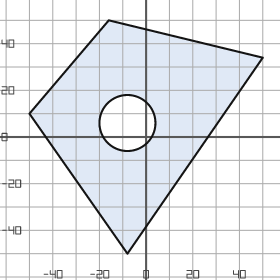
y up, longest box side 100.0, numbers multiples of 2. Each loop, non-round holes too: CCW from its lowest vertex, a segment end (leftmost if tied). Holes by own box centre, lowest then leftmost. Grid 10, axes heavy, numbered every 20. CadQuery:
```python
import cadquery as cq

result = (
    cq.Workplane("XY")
    .moveTo(-8.0, -50.0)
    .lineTo(50.0, 34.0)
    .lineTo(-16.0, 50.0)
    .lineTo(-50.0, 10.0)
    .close()
    .moveTo(-8.0, 6.0)
    .circle(12.0)
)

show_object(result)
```